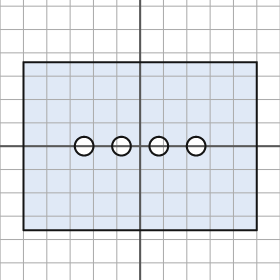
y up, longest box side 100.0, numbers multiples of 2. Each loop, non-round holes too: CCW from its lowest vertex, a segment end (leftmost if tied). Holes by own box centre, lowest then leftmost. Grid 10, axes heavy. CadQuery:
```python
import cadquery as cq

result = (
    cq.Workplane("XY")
    .moveTo(-50.0, -36.0)
    .lineTo(50.0, -36.0)
    .lineTo(50.0, 36.0)
    .lineTo(-50.0, 36.0)
    .close()
    .moveTo(-24.0, 0.0)
    .circle(4.0)
    .moveTo(-8.0, 0.0)
    .circle(4.0)
    .moveTo(8.0, 0.0)
    .circle(4.0)
    .moveTo(24.0, 0.0)
    .circle(4.0)
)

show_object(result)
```